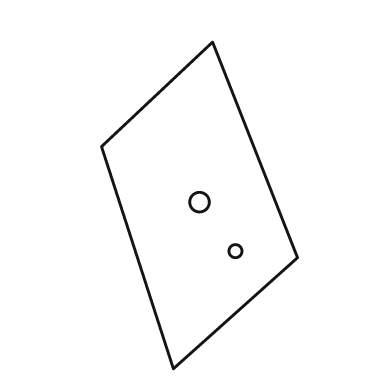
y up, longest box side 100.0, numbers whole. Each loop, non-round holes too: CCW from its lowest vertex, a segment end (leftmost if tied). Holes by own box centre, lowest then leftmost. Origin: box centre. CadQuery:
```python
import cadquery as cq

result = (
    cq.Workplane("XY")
    .moveTo(-8.0, -50.0)
    .lineTo(30.0, -16.0)
    .lineTo(4.0, 50.0)
    .lineTo(-30.0, 18.0)
    .close()
    .moveTo(11.0, -14.0)
    .circle(2.0)
    .moveTo(0.0, 1.0)
    .circle(3.0)
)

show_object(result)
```